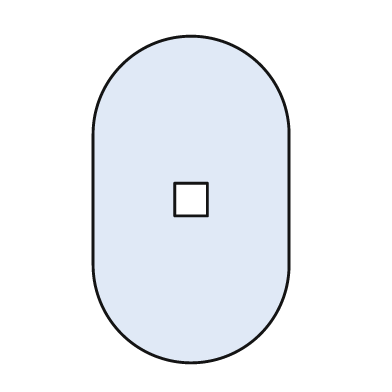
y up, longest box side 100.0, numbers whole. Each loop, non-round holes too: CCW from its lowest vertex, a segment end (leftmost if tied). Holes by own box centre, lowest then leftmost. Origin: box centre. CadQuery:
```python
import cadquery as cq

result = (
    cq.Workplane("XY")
    .moveTo(-30.0, -20.0)
    .threePointArc((0.0, -50.0), (30.0, -20.0))
    .lineTo(30.0, 20.0)
    .threePointArc((0.0, 50.0), (-30.0, 20.0))
    .close()
    .moveTo(-5.0, -5.0)
    .lineTo(5.0, -5.0)
    .lineTo(5.0, 5.0)
    .lineTo(-5.0, 5.0)
    .close()
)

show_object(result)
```